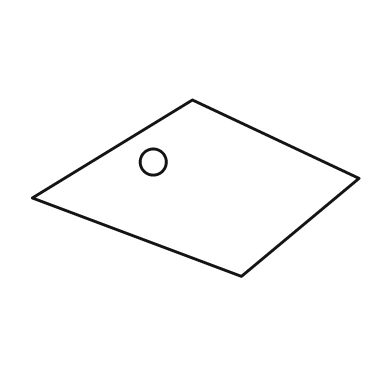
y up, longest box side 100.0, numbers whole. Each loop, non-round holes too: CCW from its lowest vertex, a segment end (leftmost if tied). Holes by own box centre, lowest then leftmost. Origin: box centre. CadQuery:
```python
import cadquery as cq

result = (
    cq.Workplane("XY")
    .moveTo(14.0, -27.0)
    .lineTo(50.0, 3.0)
    .lineTo(-1.0, 27.0)
    .lineTo(-50.0, -3.0)
    .close()
    .moveTo(-13.0, 8.0)
    .circle(4.0)
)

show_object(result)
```